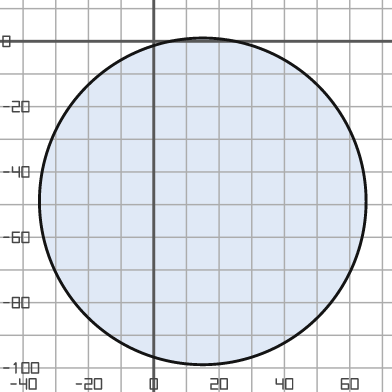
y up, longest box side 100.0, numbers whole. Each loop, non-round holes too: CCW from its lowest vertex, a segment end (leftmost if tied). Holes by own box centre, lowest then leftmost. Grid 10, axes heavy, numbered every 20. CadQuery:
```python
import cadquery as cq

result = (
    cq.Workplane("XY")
    .moveTo(15.0, -49.0)
    .circle(50.0)
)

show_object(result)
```